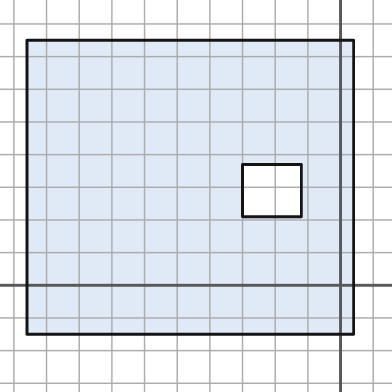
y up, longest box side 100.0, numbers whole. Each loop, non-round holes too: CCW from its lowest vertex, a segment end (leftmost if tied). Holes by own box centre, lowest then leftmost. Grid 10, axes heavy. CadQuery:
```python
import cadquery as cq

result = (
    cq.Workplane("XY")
    .moveTo(-96.0, -15.0)
    .lineTo(4.0, -15.0)
    .lineTo(4.0, 75.0)
    .lineTo(-96.0, 75.0)
    .close()
    .moveTo(-30.0, 21.0)
    .lineTo(-12.0, 21.0)
    .lineTo(-12.0, 37.0)
    .lineTo(-30.0, 37.0)
    .close()
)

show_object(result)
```